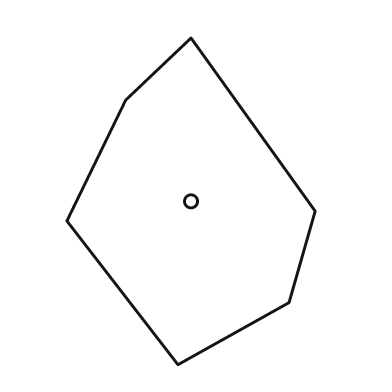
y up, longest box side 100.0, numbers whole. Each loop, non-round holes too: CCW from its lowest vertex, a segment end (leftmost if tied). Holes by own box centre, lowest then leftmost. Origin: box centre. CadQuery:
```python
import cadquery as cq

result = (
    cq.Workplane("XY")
    .moveTo(-4.0, -50.0)
    .lineTo(30.0, -31.0)
    .lineTo(38.0, -3.0)
    .lineTo(0.0, 50.0)
    .lineTo(-20.0, 31.0)
    .lineTo(-38.0, -6.0)
    .close()
    .moveTo(0.0, 0.0)
    .circle(2.0)
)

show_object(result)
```